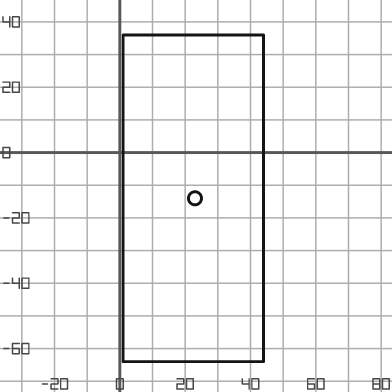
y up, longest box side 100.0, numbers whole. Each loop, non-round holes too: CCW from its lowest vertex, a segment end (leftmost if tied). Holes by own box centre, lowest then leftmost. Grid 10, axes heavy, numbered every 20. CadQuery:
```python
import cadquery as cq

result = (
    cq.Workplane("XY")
    .moveTo(1.0, -64.0)
    .lineTo(44.0, -64.0)
    .lineTo(44.0, 36.0)
    .lineTo(1.0, 36.0)
    .close()
    .moveTo(23.0, -14.0)
    .circle(2.0)
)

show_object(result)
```